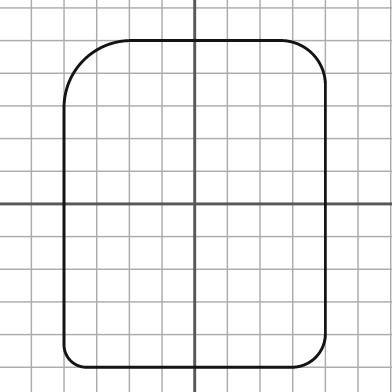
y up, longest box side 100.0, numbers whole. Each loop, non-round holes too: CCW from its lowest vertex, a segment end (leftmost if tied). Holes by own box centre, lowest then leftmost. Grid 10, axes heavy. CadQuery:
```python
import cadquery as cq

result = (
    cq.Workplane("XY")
    .moveTo(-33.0, -50.0)
    .lineTo(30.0, -50.0)
    .threePointArc((37.0, -47.0), (40.0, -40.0))
    .lineTo(40.0, 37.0)
    .threePointArc((36.0, 46.0), (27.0, 50.0))
    .lineTo(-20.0, 50.0)
    .threePointArc((-34.0, 44.0), (-40.0, 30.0))
    .lineTo(-40.0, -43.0)
    .threePointArc((-38.0, -48.0), (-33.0, -50.0))
    .close()
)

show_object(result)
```